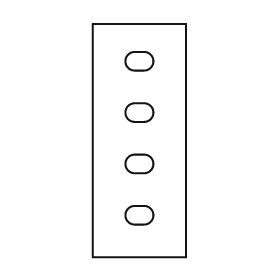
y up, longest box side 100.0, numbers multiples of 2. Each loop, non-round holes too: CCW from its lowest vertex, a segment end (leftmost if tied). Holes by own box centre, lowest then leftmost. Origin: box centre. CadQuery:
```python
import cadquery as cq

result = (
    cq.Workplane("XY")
    .moveTo(-20.0, -50.0)
    .lineTo(20.0, -50.0)
    .lineTo(20.0, 50.0)
    .lineTo(-20.0, 50.0)
    .close()
    .moveTo(-2.0, -36.0)
    .lineTo(2.0, -36.0)
    .threePointArc((6.0, -32.0), (2.0, -28.0))
    .lineTo(-2.0, -28.0)
    .threePointArc((-6.0, -32.0), (-2.0, -36.0))
    .close()
    .moveTo(-2.0, -14.0)
    .lineTo(2.0, -14.0)
    .threePointArc((6.0, -10.0), (2.0, -6.0))
    .lineTo(-2.0, -6.0)
    .threePointArc((-6.0, -10.0), (-2.0, -14.0))
    .close()
    .moveTo(-2.0, 8.0)
    .lineTo(2.0, 8.0)
    .threePointArc((6.0, 12.0), (2.0, 16.0))
    .lineTo(-2.0, 16.0)
    .threePointArc((-6.0, 12.0), (-2.0, 8.0))
    .close()
    .moveTo(-2.0, 30.0)
    .lineTo(2.0, 30.0)
    .threePointArc((6.0, 34.0), (2.0, 38.0))
    .lineTo(-2.0, 38.0)
    .threePointArc((-6.0, 34.0), (-2.0, 30.0))
    .close()
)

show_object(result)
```